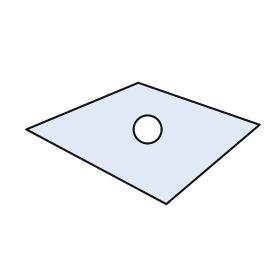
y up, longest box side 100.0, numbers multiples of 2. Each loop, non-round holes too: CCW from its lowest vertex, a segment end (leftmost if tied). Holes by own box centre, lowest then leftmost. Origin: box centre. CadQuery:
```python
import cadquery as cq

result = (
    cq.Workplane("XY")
    .moveTo(10.0, -26.0)
    .lineTo(50.0, 8.0)
    .lineTo(-2.0, 26.0)
    .lineTo(-50.0, 6.0)
    .close()
    .moveTo(2.0, 6.0)
    .circle(6.0)
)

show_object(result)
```